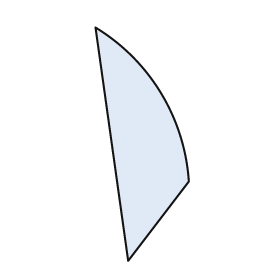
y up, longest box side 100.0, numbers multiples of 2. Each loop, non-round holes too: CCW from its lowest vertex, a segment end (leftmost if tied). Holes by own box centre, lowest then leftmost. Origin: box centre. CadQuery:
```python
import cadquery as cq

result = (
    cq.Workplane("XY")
    .moveTo(-6.0, -50.0)
    .lineTo(20.0, -16.0)
    .threePointArc((8.0, 22.0), (-20.0, 50.0))
    .close()
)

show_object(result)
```